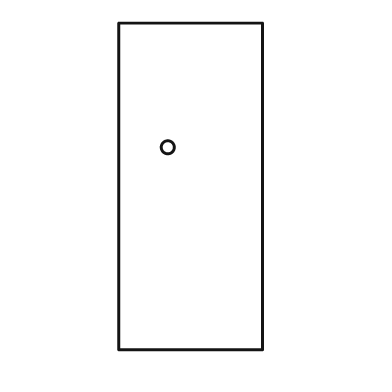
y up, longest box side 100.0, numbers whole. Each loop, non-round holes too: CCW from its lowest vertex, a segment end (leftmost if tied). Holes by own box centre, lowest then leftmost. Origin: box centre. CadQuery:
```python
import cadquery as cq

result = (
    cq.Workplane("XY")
    .moveTo(-22.0, -50.0)
    .lineTo(22.0, -50.0)
    .lineTo(22.0, 50.0)
    .lineTo(-22.0, 50.0)
    .close()
    .moveTo(-7.0, 12.0)
    .circle(2.0)
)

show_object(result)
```